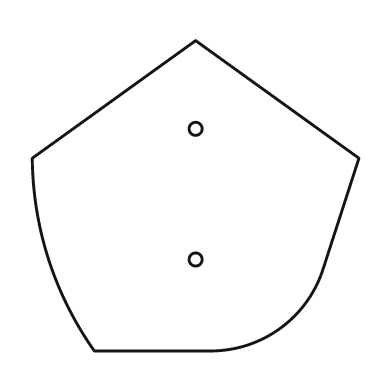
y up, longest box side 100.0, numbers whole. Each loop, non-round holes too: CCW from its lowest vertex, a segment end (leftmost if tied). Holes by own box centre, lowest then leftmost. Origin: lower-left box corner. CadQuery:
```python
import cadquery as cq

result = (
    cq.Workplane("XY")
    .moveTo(19.0, 0.0)
    .lineTo(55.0, 0.0)
    .threePointArc((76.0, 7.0), (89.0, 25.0))
    .lineTo(100.0, 59.0)
    .lineTo(50.0, 95.0)
    .lineTo(0.0, 59.0)
    .threePointArc((5.0, 28.0), (19.0, 0.0))
    .close()
    .moveTo(50.0, 28.0)
    .circle(2.0)
    .moveTo(50.0, 68.0)
    .circle(2.0)
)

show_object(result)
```